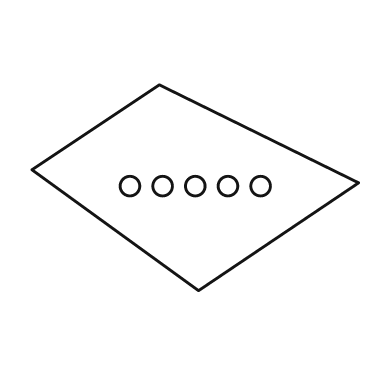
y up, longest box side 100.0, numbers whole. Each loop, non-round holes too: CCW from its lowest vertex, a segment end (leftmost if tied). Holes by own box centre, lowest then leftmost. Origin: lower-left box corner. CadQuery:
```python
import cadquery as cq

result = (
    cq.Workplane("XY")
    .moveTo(51.0, 0.0)
    .lineTo(100.0, 33.0)
    .lineTo(39.0, 63.0)
    .lineTo(0.0, 37.0)
    .close()
    .moveTo(30.0, 32.0)
    .circle(3.0)
    .moveTo(40.0, 32.0)
    .circle(3.0)
    .moveTo(50.0, 32.0)
    .circle(3.0)
    .moveTo(60.0, 32.0)
    .circle(3.0)
    .moveTo(70.0, 32.0)
    .circle(3.0)
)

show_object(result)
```